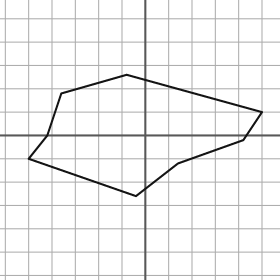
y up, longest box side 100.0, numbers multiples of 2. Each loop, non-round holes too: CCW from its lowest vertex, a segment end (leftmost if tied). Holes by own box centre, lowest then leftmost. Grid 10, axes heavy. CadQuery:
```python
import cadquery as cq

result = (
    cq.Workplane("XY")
    .moveTo(-4.0, -26.0)
    .lineTo(14.0, -12.0)
    .lineTo(42.0, -2.0)
    .lineTo(50.0, 10.0)
    .lineTo(-8.0, 26.0)
    .lineTo(-36.0, 18.0)
    .lineTo(-42.0, 0.0)
    .lineTo(-50.0, -10.0)
    .close()
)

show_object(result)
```